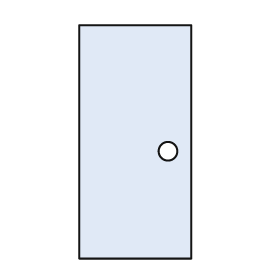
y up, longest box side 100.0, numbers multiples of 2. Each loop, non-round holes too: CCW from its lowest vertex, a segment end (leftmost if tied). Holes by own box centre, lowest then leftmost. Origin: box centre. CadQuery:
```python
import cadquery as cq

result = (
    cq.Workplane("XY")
    .moveTo(-24.0, -50.0)
    .lineTo(24.0, -50.0)
    .lineTo(24.0, 50.0)
    .lineTo(-24.0, 50.0)
    .close()
    .moveTo(14.0, -4.0)
    .circle(4.0)
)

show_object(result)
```